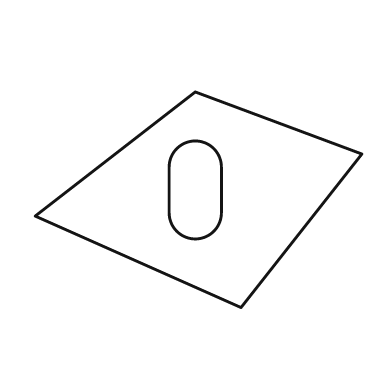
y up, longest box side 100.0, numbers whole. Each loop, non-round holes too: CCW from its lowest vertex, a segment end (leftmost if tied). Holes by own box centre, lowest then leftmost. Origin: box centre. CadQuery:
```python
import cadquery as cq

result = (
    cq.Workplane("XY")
    .moveTo(13.0, -33.0)
    .lineTo(50.0, 14.0)
    .lineTo(-1.0, 33.0)
    .lineTo(-50.0, -5.0)
    .close()
    .moveTo(-9.0, -4.0)
    .threePointArc((-1.0, -12.0), (7.0, -4.0))
    .lineTo(7.0, 10.0)
    .threePointArc((-1.0, 18.0), (-9.0, 10.0))
    .close()
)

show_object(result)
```